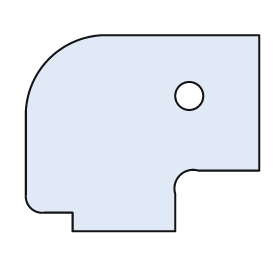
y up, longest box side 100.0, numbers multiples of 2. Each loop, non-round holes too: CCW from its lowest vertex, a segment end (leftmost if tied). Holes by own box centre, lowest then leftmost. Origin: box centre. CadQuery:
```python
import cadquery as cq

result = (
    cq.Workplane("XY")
    .moveTo(-30.0, -42.0)
    .lineTo(14.0, -42.0)
    .lineTo(14.0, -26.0)
    .threePointArc((16.0, -18.0), (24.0, -16.0))
    .lineTo(50.0, -16.0)
    .lineTo(50.0, 42.0)
    .lineTo(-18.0, 42.0)
    .threePointArc((-40.0, 32.0), (-50.0, 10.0))
    .lineTo(-50.0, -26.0)
    .threePointArc((-48.0, -32.0), (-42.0, -34.0))
    .lineTo(-30.0, -34.0)
    .close()
    .moveTo(20.0, 16.0)
    .circle(6.0)
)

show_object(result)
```